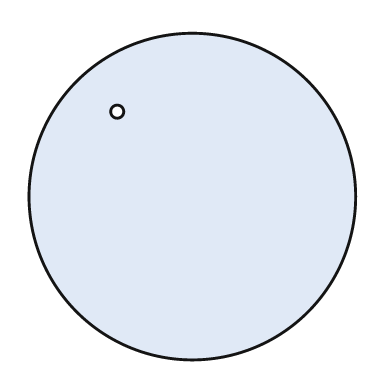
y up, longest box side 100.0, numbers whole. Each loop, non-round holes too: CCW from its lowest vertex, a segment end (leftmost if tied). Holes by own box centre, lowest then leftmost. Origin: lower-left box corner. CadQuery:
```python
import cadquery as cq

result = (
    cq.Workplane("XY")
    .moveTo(50.0, 50.0)
    .circle(50.0)
    .moveTo(27.0, 76.0)
    .circle(2.0)
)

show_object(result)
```